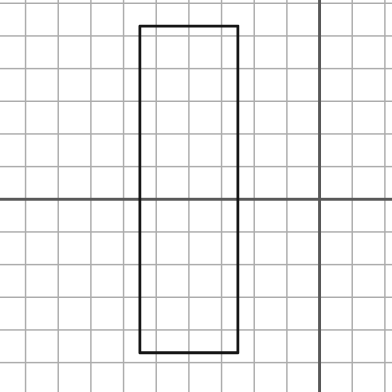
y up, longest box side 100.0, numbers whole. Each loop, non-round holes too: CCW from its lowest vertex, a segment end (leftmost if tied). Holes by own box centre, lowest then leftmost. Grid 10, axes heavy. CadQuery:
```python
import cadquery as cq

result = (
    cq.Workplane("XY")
    .moveTo(-55.0, -47.0)
    .lineTo(-25.0, -47.0)
    .lineTo(-25.0, 53.0)
    .lineTo(-55.0, 53.0)
    .close()
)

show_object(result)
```